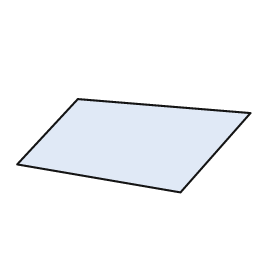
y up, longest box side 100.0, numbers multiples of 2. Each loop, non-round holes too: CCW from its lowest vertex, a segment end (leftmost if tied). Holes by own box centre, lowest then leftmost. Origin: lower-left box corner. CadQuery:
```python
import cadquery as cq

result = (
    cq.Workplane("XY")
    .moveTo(70.0, 0.0)
    .lineTo(100.0, 34.0)
    .lineTo(26.0, 40.0)
    .lineTo(0.0, 12.0)
    .close()
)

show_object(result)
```